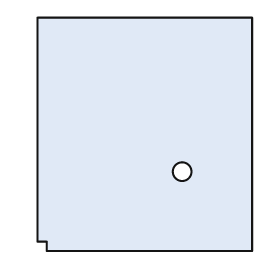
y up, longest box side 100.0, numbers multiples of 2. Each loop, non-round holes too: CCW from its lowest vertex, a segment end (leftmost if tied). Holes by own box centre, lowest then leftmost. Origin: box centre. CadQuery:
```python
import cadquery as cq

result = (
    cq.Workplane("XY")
    .moveTo(-42.0, -50.0)
    .lineTo(46.0, -50.0)
    .lineTo(46.0, 50.0)
    .lineTo(-46.0, 50.0)
    .lineTo(-46.0, -46.0)
    .lineTo(-42.0, -46.0)
    .close()
    .moveTo(16.0, -16.0)
    .circle(4.0)
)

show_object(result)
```